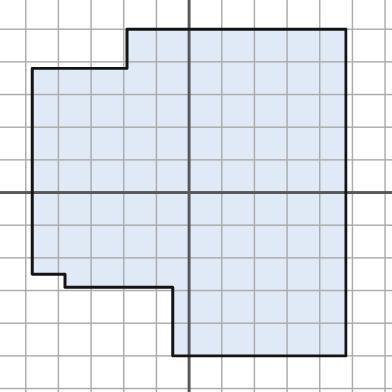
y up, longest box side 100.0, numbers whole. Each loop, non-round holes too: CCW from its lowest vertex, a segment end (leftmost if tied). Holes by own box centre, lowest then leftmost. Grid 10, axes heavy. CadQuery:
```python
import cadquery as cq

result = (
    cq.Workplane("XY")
    .moveTo(-5.0, -50.0)
    .lineTo(48.0, -50.0)
    .lineTo(48.0, 50.0)
    .lineTo(-19.0, 50.0)
    .lineTo(-19.0, 38.0)
    .lineTo(-48.0, 38.0)
    .lineTo(-48.0, -25.0)
    .lineTo(-38.0, -25.0)
    .lineTo(-38.0, -29.0)
    .lineTo(-5.0, -29.0)
    .close()
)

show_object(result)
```